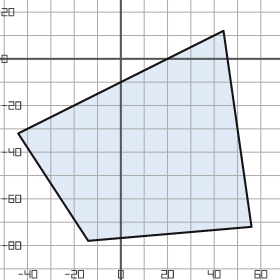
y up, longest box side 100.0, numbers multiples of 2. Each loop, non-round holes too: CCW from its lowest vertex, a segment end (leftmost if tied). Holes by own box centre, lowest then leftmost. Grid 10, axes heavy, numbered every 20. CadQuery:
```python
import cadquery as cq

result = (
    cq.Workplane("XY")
    .moveTo(-14.0, -78.0)
    .lineTo(56.0, -72.0)
    .lineTo(44.0, 12.0)
    .lineTo(-44.0, -32.0)
    .close()
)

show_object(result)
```